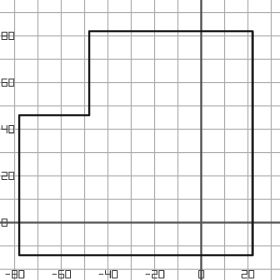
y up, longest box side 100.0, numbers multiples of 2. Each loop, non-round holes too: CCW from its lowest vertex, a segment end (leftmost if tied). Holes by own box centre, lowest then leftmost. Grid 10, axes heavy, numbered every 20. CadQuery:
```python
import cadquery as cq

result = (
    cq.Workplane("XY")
    .moveTo(-78.0, -14.0)
    .lineTo(22.0, -14.0)
    .lineTo(22.0, 82.0)
    .lineTo(-48.0, 82.0)
    .lineTo(-48.0, 46.0)
    .lineTo(-78.0, 46.0)
    .close()
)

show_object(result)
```